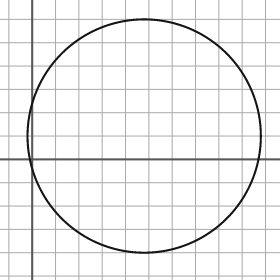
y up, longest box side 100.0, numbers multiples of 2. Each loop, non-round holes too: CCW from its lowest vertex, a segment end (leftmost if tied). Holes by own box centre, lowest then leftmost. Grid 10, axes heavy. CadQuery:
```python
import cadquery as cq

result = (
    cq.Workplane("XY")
    .moveTo(48.0, 10.0)
    .circle(50.0)
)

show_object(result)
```